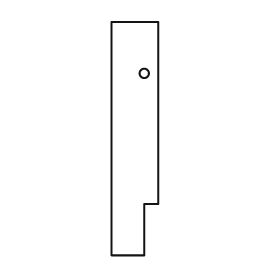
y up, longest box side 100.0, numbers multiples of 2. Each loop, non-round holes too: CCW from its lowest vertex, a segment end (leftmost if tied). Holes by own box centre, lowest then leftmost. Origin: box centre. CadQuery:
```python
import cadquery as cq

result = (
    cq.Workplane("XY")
    .moveTo(-10.0, -50.0)
    .lineTo(4.0, -50.0)
    .lineTo(4.0, -28.0)
    .lineTo(10.0, -28.0)
    .lineTo(10.0, 50.0)
    .lineTo(-10.0, 50.0)
    .close()
    .moveTo(4.0, 28.0)
    .circle(2.0)
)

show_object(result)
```